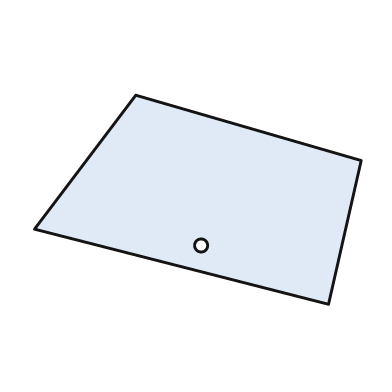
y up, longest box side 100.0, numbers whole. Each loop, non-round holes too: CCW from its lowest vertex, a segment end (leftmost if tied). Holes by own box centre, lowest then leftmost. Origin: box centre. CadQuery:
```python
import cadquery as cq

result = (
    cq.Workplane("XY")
    .moveTo(40.0, -32.0)
    .lineTo(50.0, 12.0)
    .lineTo(-19.0, 32.0)
    .lineTo(-50.0, -9.0)
    .close()
    .moveTo(1.0, -14.0)
    .circle(2.0)
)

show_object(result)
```